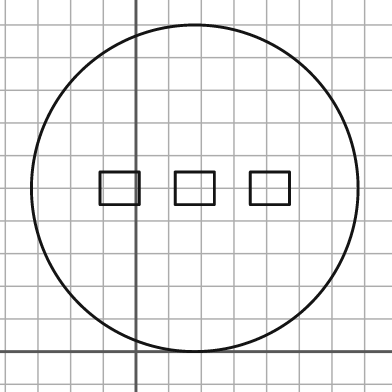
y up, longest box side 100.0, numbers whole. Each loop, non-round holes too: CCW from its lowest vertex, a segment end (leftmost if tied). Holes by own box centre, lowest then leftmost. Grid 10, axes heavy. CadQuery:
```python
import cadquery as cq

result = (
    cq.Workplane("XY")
    .moveTo(18.0, 50.0)
    .circle(50.0)
    .moveTo(-11.0, 45.0)
    .lineTo(1.0, 45.0)
    .lineTo(1.0, 55.0)
    .lineTo(-11.0, 55.0)
    .close()
    .moveTo(12.0, 45.0)
    .lineTo(24.0, 45.0)
    .lineTo(24.0, 55.0)
    .lineTo(12.0, 55.0)
    .close()
    .moveTo(35.0, 45.0)
    .lineTo(47.0, 45.0)
    .lineTo(47.0, 55.0)
    .lineTo(35.0, 55.0)
    .close()
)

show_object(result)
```